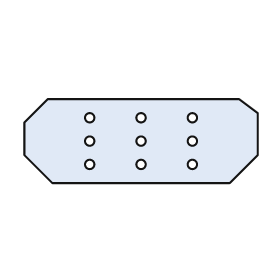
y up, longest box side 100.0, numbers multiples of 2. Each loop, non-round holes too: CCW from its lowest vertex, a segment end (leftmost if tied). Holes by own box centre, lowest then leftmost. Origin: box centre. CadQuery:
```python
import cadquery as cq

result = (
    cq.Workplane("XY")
    .moveTo(-38.0, -18.0)
    .lineTo(38.0, -18.0)
    .lineTo(50.0, -6.0)
    .lineTo(50.0, 12.0)
    .lineTo(42.0, 18.0)
    .lineTo(-40.0, 18.0)
    .lineTo(-50.0, 8.0)
    .lineTo(-50.0, -6.0)
    .close()
    .moveTo(-22.0, -10.0)
    .circle(2.0)
    .moveTo(0.0, -10.0)
    .circle(2.0)
    .moveTo(22.0, -10.0)
    .circle(2.0)
    .moveTo(-22.0, 0.0)
    .circle(2.0)
    .moveTo(0.0, 0.0)
    .circle(2.0)
    .moveTo(22.0, 0.0)
    .circle(2.0)
    .moveTo(-22.0, 10.0)
    .circle(2.0)
    .moveTo(0.0, 10.0)
    .circle(2.0)
    .moveTo(22.0, 10.0)
    .circle(2.0)
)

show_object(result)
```